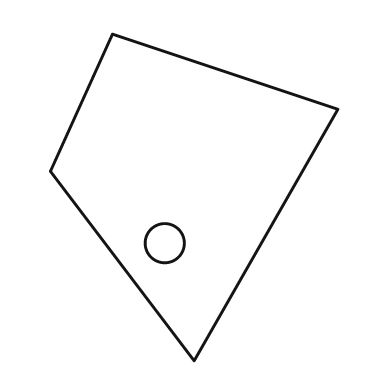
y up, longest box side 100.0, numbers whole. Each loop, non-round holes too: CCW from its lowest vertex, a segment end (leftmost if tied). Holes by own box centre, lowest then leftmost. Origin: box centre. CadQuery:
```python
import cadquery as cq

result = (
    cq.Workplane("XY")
    .moveTo(0.0, -50.0)
    .lineTo(44.0, 27.0)
    .lineTo(-25.0, 50.0)
    .lineTo(-44.0, 8.0)
    .close()
    .moveTo(-9.0, -14.0)
    .circle(6.0)
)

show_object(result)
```